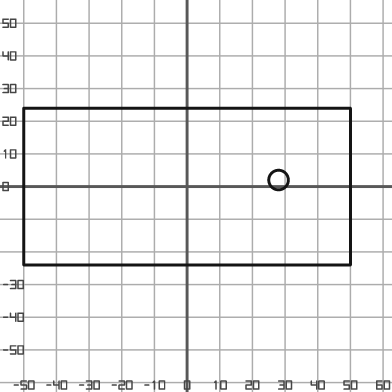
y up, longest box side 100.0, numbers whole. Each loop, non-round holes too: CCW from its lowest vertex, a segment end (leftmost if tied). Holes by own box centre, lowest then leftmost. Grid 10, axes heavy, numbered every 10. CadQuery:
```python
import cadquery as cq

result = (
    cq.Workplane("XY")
    .moveTo(-50.0, -24.0)
    .lineTo(50.0, -24.0)
    .lineTo(50.0, 24.0)
    .lineTo(-50.0, 24.0)
    .close()
    .moveTo(28.0, 2.0)
    .circle(3.0)
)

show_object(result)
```